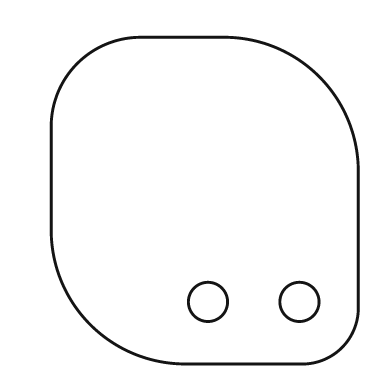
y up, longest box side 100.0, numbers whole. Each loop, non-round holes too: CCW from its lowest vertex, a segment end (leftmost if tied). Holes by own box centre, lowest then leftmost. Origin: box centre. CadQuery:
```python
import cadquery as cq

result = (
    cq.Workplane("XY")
    .moveTo(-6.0, -50.0)
    .lineTo(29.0, -50.0)
    .threePointArc((42.0, -45.0), (47.0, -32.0))
    .lineTo(47.0, 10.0)
    .threePointArc((35.0, 38.0), (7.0, 50.0))
    .lineTo(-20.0, 50.0)
    .threePointArc((-39.0, 42.0), (-47.0, 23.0))
    .lineTo(-47.0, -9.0)
    .threePointArc((-35.0, -38.0), (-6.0, -50.0))
    .close()
    .moveTo(1.0, -31.0)
    .circle(6.0)
    .moveTo(29.0, -31.0)
    .circle(6.0)
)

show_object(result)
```